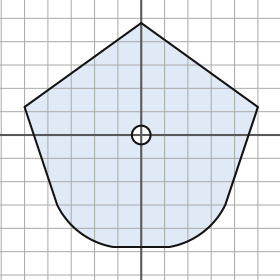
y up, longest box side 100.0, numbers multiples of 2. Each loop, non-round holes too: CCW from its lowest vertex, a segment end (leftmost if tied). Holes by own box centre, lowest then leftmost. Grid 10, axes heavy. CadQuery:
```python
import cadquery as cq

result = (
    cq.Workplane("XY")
    .moveTo(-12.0, -48.0)
    .lineTo(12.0, -48.0)
    .threePointArc((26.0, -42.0), (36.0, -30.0))
    .lineTo(50.0, 12.0)
    .lineTo(0.0, 48.0)
    .lineTo(-50.0, 12.0)
    .lineTo(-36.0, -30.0)
    .threePointArc((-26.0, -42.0), (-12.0, -48.0))
    .close()
    .moveTo(0.0, 0.0)
    .circle(4.0)
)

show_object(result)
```